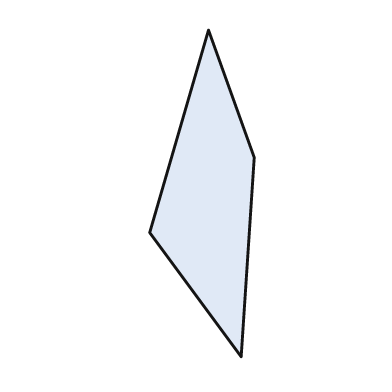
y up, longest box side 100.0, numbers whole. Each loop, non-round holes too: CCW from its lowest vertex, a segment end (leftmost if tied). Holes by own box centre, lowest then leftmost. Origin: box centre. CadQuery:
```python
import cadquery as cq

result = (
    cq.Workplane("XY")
    .moveTo(12.0, -50.0)
    .lineTo(16.0, 11.0)
    .lineTo(2.0, 50.0)
    .lineTo(-16.0, -12.0)
    .close()
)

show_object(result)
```